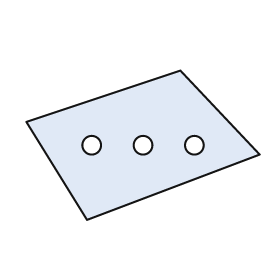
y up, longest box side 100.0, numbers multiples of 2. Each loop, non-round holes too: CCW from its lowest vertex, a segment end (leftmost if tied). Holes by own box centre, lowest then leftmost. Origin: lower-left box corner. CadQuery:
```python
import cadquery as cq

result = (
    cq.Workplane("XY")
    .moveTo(26.0, 0.0)
    .lineTo(100.0, 28.0)
    .lineTo(66.0, 64.0)
    .lineTo(0.0, 42.0)
    .close()
    .moveTo(28.0, 32.0)
    .circle(4.0)
    .moveTo(50.0, 32.0)
    .circle(4.0)
    .moveTo(72.0, 32.0)
    .circle(4.0)
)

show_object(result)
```